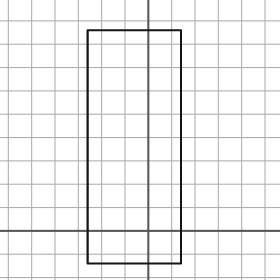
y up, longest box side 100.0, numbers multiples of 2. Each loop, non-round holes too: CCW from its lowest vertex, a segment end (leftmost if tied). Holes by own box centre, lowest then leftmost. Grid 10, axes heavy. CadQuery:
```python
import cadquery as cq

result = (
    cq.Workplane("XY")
    .moveTo(-26.0, -14.0)
    .lineTo(14.0, -14.0)
    .lineTo(14.0, 86.0)
    .lineTo(-26.0, 86.0)
    .close()
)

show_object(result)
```